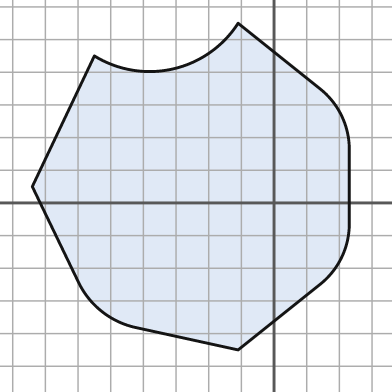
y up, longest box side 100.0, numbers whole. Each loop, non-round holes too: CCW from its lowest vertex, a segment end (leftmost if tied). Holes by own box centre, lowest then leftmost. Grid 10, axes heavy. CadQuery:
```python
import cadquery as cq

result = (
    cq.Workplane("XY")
    .moveTo(-11.0, -45.0)
    .lineTo(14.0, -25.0)
    .threePointArc((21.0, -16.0), (23.0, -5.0))
    .lineTo(23.0, 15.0)
    .threePointArc((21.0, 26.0), (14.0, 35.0))
    .lineTo(-11.0, 55.0)
    .threePointArc((-31.0, 41.0), (-55.0, 45.0))
    .lineTo(-74.0, 5.0)
    .lineTo(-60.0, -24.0)
    .threePointArc((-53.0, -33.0), (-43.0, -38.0))
    .close()
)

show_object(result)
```